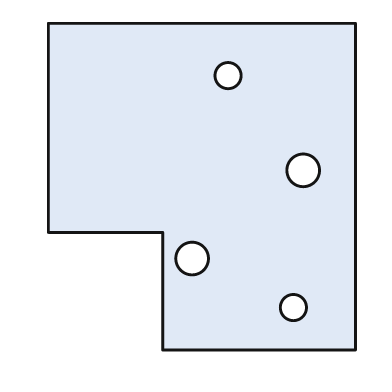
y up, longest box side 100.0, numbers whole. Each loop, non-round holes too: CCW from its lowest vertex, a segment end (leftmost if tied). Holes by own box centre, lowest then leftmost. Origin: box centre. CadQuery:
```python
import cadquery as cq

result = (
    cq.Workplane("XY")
    .moveTo(-12.0, -50.0)
    .lineTo(47.0, -50.0)
    .lineTo(47.0, 50.0)
    .lineTo(-47.0, 50.0)
    .lineTo(-47.0, -14.0)
    .lineTo(-12.0, -14.0)
    .close()
    .moveTo(28.0, -37.0)
    .circle(4.0)
    .moveTo(-3.0, -22.0)
    .circle(5.0)
    .moveTo(31.0, 5.0)
    .circle(5.0)
    .moveTo(8.0, 34.0)
    .circle(4.0)
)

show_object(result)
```